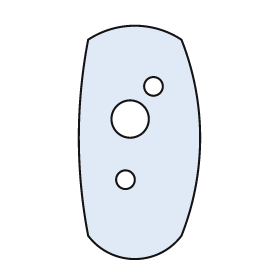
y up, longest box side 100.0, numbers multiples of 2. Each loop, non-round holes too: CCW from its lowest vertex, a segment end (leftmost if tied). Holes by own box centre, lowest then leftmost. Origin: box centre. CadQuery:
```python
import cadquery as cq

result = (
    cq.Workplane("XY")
    .moveTo(-22.0, -40.0)
    .threePointArc((-2.0, -50.0), (18.0, -40.0))
    .threePointArc((26.0, 2.0), (18.0, 44.0))
    .threePointArc((-2.0, 50.0), (-22.0, 44.0))
    .threePointArc((-26.0, 2.0), (-22.0, -40.0))
    .close()
    .moveTo(-6.0, -16.0)
    .circle(4.0)
    .moveTo(-4.0, 10.0)
    .circle(8.0)
    .moveTo(6.0, 24.0)
    .circle(4.0)
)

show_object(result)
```